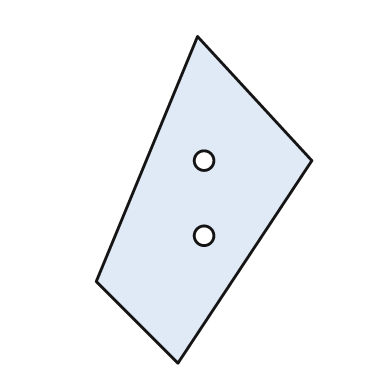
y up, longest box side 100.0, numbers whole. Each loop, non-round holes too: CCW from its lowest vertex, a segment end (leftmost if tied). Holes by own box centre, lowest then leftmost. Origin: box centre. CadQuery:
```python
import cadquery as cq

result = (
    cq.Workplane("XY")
    .moveTo(-8.0, -50.0)
    .lineTo(33.0, 12.0)
    .lineTo(-2.0, 50.0)
    .lineTo(-33.0, -25.0)
    .close()
    .moveTo(0.0, -11.0)
    .circle(3.0)
    .moveTo(0.0, 12.0)
    .circle(3.0)
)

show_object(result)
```